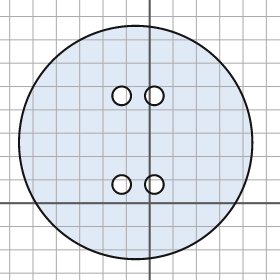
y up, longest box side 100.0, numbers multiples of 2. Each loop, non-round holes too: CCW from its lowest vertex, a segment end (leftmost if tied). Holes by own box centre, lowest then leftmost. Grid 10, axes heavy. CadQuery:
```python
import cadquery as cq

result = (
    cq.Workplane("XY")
    .moveTo(-6.0, 26.0)
    .circle(50.0)
    .moveTo(-12.0, 8.0)
    .circle(4.0)
    .moveTo(2.0, 8.0)
    .circle(4.0)
    .moveTo(-12.0, 46.0)
    .circle(4.0)
    .moveTo(2.0, 46.0)
    .circle(4.0)
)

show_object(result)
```